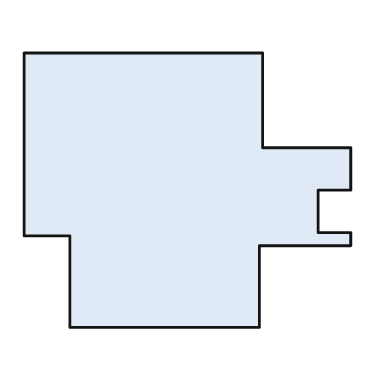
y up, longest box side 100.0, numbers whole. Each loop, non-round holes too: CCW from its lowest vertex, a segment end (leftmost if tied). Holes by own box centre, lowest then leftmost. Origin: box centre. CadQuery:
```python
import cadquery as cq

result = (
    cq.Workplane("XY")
    .moveTo(-36.0, -42.0)
    .lineTo(22.0, -42.0)
    .lineTo(22.0, -17.0)
    .lineTo(50.0, -17.0)
    .lineTo(50.0, -13.0)
    .lineTo(40.0, -13.0)
    .lineTo(40.0, 0.0)
    .lineTo(50.0, 0.0)
    .lineTo(50.0, 13.0)
    .lineTo(23.0, 13.0)
    .lineTo(23.0, 42.0)
    .lineTo(-50.0, 42.0)
    .lineTo(-50.0, -14.0)
    .lineTo(-36.0, -14.0)
    .close()
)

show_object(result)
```